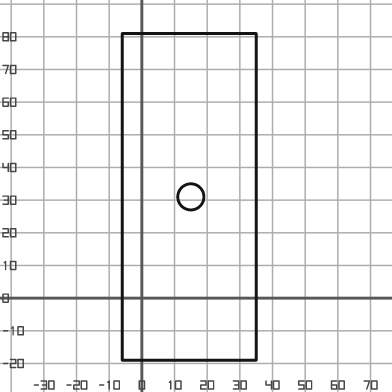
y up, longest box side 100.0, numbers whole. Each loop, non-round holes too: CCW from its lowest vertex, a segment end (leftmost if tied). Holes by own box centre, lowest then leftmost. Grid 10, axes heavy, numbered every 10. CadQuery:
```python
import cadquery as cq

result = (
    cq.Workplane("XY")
    .moveTo(-6.0, -19.0)
    .lineTo(35.0, -19.0)
    .lineTo(35.0, 81.0)
    .lineTo(-6.0, 81.0)
    .close()
    .moveTo(15.0, 31.0)
    .circle(4.0)
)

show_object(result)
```